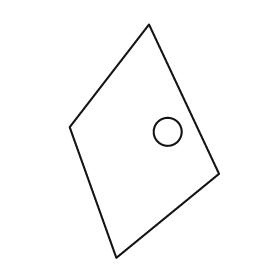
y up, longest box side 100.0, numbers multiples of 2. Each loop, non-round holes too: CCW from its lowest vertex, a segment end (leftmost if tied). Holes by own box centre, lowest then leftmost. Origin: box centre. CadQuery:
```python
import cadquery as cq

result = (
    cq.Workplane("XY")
    .moveTo(-12.0, -50.0)
    .lineTo(32.0, -14.0)
    .lineTo(2.0, 50.0)
    .lineTo(-32.0, 6.0)
    .close()
    .moveTo(10.0, 4.0)
    .circle(6.0)
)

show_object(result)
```